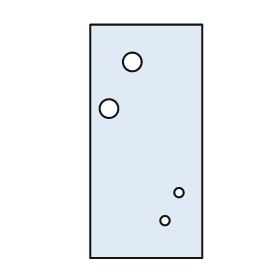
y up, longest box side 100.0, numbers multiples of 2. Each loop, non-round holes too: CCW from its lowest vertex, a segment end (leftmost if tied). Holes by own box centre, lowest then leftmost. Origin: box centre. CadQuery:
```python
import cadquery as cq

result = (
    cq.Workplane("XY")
    .moveTo(-24.0, -50.0)
    .lineTo(24.0, -50.0)
    .lineTo(24.0, 50.0)
    .lineTo(-24.0, 50.0)
    .close()
    .moveTo(8.0, -34.0)
    .circle(2.0)
    .moveTo(14.0, -22.0)
    .circle(2.0)
    .moveTo(-16.0, 14.0)
    .circle(4.0)
    .moveTo(-6.0, 34.0)
    .circle(4.0)
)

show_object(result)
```